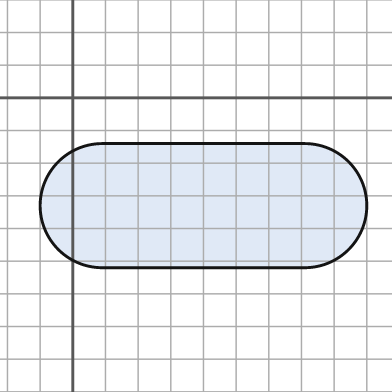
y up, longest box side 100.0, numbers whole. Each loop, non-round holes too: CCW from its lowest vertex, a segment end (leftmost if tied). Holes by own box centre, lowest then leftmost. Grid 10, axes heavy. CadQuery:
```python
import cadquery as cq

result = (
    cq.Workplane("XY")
    .moveTo(9.0, -52.0)
    .lineTo(71.0, -52.0)
    .threePointArc((90.0, -33.0), (71.0, -14.0))
    .lineTo(9.0, -14.0)
    .threePointArc((-10.0, -33.0), (9.0, -52.0))
    .close()
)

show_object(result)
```